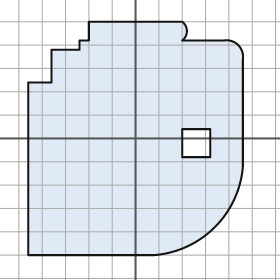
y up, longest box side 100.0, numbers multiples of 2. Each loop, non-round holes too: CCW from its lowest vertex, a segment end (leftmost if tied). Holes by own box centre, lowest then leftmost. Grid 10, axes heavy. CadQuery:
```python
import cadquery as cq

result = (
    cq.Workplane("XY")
    .moveTo(-46.0, -50.0)
    .lineTo(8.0, -50.0)
    .threePointArc((34.0, -38.0), (46.0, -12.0))
    .lineTo(46.0, 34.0)
    .threePointArc((44.0, 40.0), (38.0, 42.0))
    .lineTo(20.0, 42.0)
    .threePointArc((22.0, 46.0), (20.0, 50.0))
    .lineTo(-20.0, 50.0)
    .lineTo(-20.0, 42.0)
    .lineTo(-24.0, 42.0)
    .lineTo(-24.0, 38.0)
    .lineTo(-36.0, 38.0)
    .lineTo(-36.0, 24.0)
    .lineTo(-46.0, 24.0)
    .close()
    .moveTo(20.0, -8.0)
    .lineTo(32.0, -8.0)
    .lineTo(32.0, 4.0)
    .lineTo(20.0, 4.0)
    .close()
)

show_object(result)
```